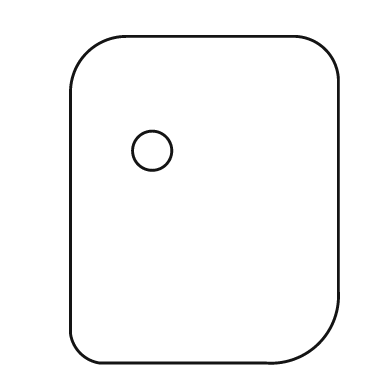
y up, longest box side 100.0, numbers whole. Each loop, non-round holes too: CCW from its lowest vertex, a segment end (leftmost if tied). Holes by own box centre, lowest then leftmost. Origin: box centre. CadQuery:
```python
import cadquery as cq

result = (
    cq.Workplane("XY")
    .moveTo(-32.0, -50.0)
    .lineTo(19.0, -50.0)
    .threePointArc((35.0, -44.0), (41.0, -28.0))
    .lineTo(41.0, 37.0)
    .threePointArc((37.0, 46.0), (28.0, 50.0))
    .lineTo(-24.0, 50.0)
    .threePointArc((-36.0, 45.0), (-41.0, 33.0))
    .lineTo(-41.0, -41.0)
    .threePointArc((-38.0, -47.0), (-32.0, -50.0))
    .close()
    .moveTo(-16.0, 15.0)
    .circle(6.0)
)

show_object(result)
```